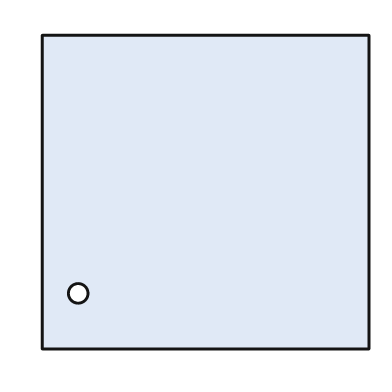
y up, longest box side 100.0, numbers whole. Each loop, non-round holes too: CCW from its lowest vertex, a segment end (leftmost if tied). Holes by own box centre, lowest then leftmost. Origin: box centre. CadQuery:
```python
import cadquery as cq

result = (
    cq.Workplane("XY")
    .moveTo(-50.0, -48.0)
    .lineTo(50.0, -48.0)
    .lineTo(50.0, 48.0)
    .lineTo(-50.0, 48.0)
    .close()
    .moveTo(-39.0, -31.0)
    .circle(3.0)
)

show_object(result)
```